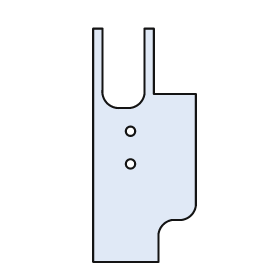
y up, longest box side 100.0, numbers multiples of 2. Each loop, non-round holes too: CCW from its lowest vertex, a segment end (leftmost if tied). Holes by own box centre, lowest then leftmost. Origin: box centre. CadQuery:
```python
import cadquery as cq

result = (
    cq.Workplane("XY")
    .moveTo(-22.0, -50.0)
    .lineTo(6.0, -50.0)
    .lineTo(6.0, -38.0)
    .threePointArc((8.0, -34.0), (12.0, -32.0))
    .lineTo(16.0, -32.0)
    .threePointArc((20.0, -30.0), (22.0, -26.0))
    .lineTo(22.0, 22.0)
    .lineTo(4.0, 22.0)
    .lineTo(4.0, 50.0)
    .lineTo(0.0, 50.0)
    .lineTo(0.0, 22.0)
    .threePointArc((-2.0, 18.0), (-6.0, 16.0))
    .lineTo(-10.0, 16.0)
    .threePointArc((-16.0, 18.0), (-18.0, 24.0))
    .lineTo(-18.0, 50.0)
    .lineTo(-22.0, 50.0)
    .close()
    .moveTo(-6.0, -8.0)
    .circle(2.0)
    .moveTo(-6.0, 6.0)
    .circle(2.0)
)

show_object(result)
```